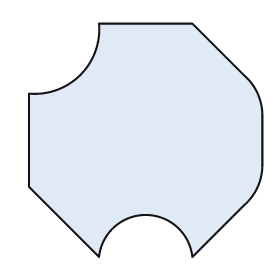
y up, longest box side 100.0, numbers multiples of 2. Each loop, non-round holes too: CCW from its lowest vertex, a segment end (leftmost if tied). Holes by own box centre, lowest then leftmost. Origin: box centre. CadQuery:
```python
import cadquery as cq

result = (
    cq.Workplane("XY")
    .moveTo(-20.0, -50.0)
    .threePointArc((0.0, -32.0), (20.0, -50.0))
    .lineTo(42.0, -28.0)
    .threePointArc((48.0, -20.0), (50.0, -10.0))
    .lineTo(50.0, 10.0)
    .threePointArc((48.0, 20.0), (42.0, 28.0))
    .lineTo(20.0, 50.0)
    .lineTo(-20.0, 50.0)
    .threePointArc((-28.0, 28.0), (-50.0, 20.0))
    .lineTo(-50.0, -20.0)
    .close()
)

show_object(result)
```